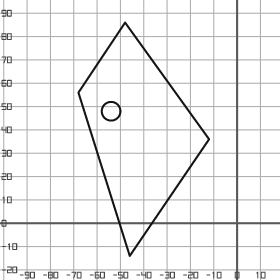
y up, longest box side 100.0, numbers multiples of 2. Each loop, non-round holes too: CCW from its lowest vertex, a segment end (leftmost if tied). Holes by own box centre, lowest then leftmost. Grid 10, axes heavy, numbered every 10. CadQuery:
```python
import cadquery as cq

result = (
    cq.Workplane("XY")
    .moveTo(-46.0, -14.0)
    .lineTo(-12.0, 36.0)
    .lineTo(-48.0, 86.0)
    .lineTo(-68.0, 56.0)
    .close()
    .moveTo(-54.0, 48.0)
    .circle(4.0)
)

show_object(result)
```